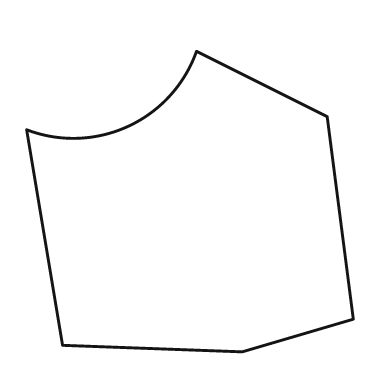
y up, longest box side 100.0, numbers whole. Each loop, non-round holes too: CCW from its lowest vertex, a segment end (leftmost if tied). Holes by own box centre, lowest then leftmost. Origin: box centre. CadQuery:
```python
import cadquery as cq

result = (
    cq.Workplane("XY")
    .moveTo(16.0, -46.0)
    .lineTo(50.0, -36.0)
    .lineTo(42.0, 26.0)
    .lineTo(2.0, 46.0)
    .threePointArc((-19.0, 23.0), (-50.0, 22.0))
    .lineTo(-39.0, -44.0)
    .close()
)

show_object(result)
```